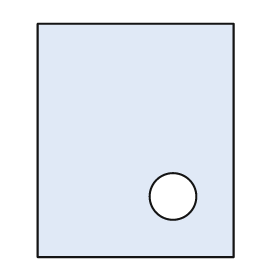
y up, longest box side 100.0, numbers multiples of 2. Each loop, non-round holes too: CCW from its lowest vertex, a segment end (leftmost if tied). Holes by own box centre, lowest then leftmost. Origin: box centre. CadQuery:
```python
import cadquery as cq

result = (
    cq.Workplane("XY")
    .moveTo(-42.0, -50.0)
    .lineTo(42.0, -50.0)
    .lineTo(42.0, 50.0)
    .lineTo(-42.0, 50.0)
    .close()
    .moveTo(16.0, -24.0)
    .circle(10.0)
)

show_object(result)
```